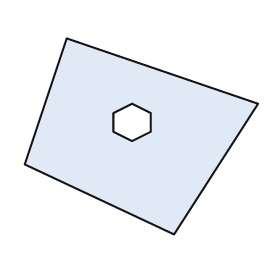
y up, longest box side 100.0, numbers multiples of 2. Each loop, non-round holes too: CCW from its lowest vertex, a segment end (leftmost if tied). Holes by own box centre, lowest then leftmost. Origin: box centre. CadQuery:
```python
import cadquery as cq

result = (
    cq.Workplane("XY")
    .moveTo(14.0, -42.0)
    .lineTo(50.0, 14.0)
    .lineTo(-32.0, 42.0)
    .lineTo(-50.0, -12.0)
    .close()
    .moveTo(-4.0, -2.0)
    .lineTo(4.0, 2.0)
    .lineTo(4.0, 10.0)
    .lineTo(-4.0, 14.0)
    .lineTo(-12.0, 10.0)
    .lineTo(-12.0, 2.0)
    .close()
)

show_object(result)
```